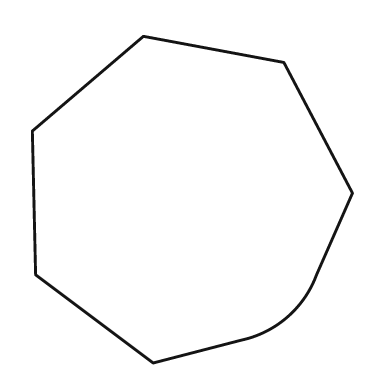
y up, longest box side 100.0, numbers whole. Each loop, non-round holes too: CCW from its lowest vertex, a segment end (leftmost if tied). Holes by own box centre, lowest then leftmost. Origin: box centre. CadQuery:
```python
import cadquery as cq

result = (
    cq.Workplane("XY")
    .moveTo(-12.0, -50.0)
    .lineTo(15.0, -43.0)
    .threePointArc((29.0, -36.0), (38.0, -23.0))
    .lineTo(49.0, 2.0)
    .lineTo(28.0, 42.0)
    .lineTo(-15.0, 50.0)
    .lineTo(-49.0, 21.0)
    .lineTo(-48.0, -23.0)
    .close()
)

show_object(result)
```